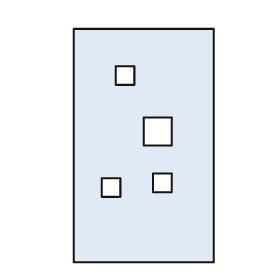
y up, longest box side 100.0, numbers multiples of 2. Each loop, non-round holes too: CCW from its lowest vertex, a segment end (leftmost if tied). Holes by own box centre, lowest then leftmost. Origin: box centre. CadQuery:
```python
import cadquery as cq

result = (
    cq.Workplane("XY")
    .moveTo(-30.0, -50.0)
    .lineTo(30.0, -50.0)
    .lineTo(30.0, 50.0)
    .lineTo(-30.0, 50.0)
    .close()
    .moveTo(-18.0, -22.0)
    .lineTo(-10.0, -22.0)
    .lineTo(-10.0, -14.0)
    .lineTo(-18.0, -14.0)
    .close()
    .moveTo(4.0, -20.0)
    .lineTo(12.0, -20.0)
    .lineTo(12.0, -12.0)
    .lineTo(4.0, -12.0)
    .close()
    .moveTo(0.0, 0.0)
    .lineTo(12.0, 0.0)
    .lineTo(12.0, 12.0)
    .lineTo(0.0, 12.0)
    .close()
    .moveTo(-12.0, 26.0)
    .lineTo(-4.0, 26.0)
    .lineTo(-4.0, 34.0)
    .lineTo(-12.0, 34.0)
    .close()
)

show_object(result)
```